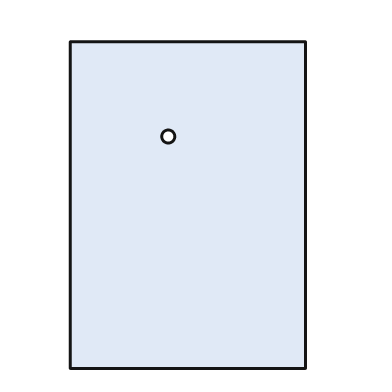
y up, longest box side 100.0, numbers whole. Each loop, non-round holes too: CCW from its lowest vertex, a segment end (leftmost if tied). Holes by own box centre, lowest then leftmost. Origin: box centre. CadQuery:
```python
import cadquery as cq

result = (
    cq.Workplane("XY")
    .moveTo(-36.0, -50.0)
    .lineTo(36.0, -50.0)
    .lineTo(36.0, 50.0)
    .lineTo(-36.0, 50.0)
    .close()
    .moveTo(-6.0, 21.0)
    .circle(2.0)
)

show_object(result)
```